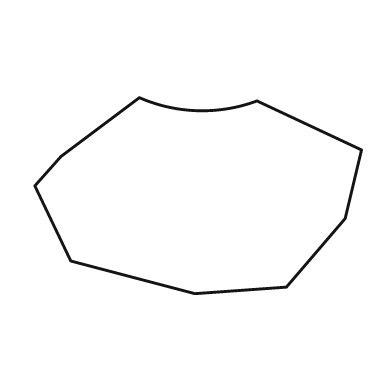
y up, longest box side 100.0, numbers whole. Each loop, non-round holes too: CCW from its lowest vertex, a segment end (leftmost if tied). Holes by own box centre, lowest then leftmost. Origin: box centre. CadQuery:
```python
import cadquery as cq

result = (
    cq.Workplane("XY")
    .moveTo(-1.0, -30.0)
    .lineTo(27.0, -28.0)
    .lineTo(45.0, -7.0)
    .lineTo(50.0, 14.0)
    .lineTo(18.0, 29.0)
    .threePointArc((0.0, 26.0), (-18.0, 30.0))
    .lineTo(-42.0, 12.0)
    .lineTo(-50.0, 3.0)
    .lineTo(-39.0, -20.0)
    .close()
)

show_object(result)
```